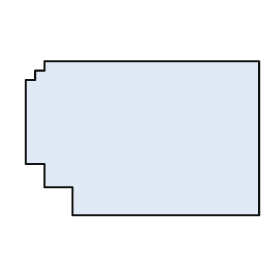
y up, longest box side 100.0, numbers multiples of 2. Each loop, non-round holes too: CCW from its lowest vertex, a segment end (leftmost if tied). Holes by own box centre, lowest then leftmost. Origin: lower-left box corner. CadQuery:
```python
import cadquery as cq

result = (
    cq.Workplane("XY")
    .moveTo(20.0, 0.0)
    .lineTo(100.0, 0.0)
    .lineTo(100.0, 66.0)
    .lineTo(8.0, 66.0)
    .lineTo(8.0, 62.0)
    .lineTo(4.0, 62.0)
    .lineTo(4.0, 58.0)
    .lineTo(0.0, 58.0)
    .lineTo(0.0, 22.0)
    .lineTo(8.0, 22.0)
    .lineTo(8.0, 12.0)
    .lineTo(20.0, 12.0)
    .close()
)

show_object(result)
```